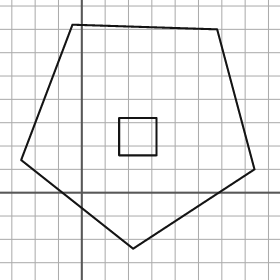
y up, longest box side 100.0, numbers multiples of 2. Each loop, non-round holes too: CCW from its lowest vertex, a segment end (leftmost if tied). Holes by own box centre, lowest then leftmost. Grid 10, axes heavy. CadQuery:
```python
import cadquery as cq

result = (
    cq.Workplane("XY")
    .moveTo(22.0, -24.0)
    .lineTo(74.0, 10.0)
    .lineTo(58.0, 70.0)
    .lineTo(-4.0, 72.0)
    .lineTo(-26.0, 14.0)
    .close()
    .moveTo(16.0, 16.0)
    .lineTo(32.0, 16.0)
    .lineTo(32.0, 32.0)
    .lineTo(16.0, 32.0)
    .close()
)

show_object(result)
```